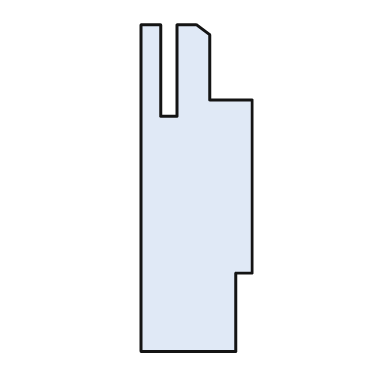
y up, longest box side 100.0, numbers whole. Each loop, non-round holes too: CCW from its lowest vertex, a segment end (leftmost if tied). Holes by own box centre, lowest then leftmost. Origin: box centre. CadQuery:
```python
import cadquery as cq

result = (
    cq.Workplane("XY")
    .moveTo(-17.0, -50.0)
    .lineTo(12.0, -50.0)
    .lineTo(12.0, -26.0)
    .lineTo(17.0, -26.0)
    .lineTo(17.0, 27.0)
    .lineTo(4.0, 27.0)
    .lineTo(4.0, 47.0)
    .lineTo(0.0, 50.0)
    .lineTo(-6.0, 50.0)
    .lineTo(-6.0, 22.0)
    .lineTo(-11.0, 22.0)
    .lineTo(-11.0, 50.0)
    .lineTo(-17.0, 50.0)
    .close()
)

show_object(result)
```